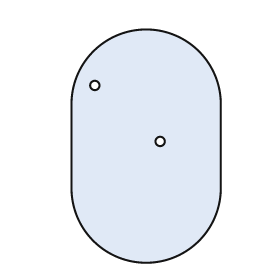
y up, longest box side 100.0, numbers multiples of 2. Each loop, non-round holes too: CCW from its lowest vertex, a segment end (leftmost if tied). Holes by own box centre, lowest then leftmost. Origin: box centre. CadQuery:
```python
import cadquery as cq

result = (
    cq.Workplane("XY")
    .moveTo(-32.0, -18.0)
    .threePointArc((0.0, -50.0), (32.0, -18.0))
    .lineTo(32.0, 18.0)
    .threePointArc((0.0, 50.0), (-32.0, 18.0))
    .close()
    .moveTo(6.0, 2.0)
    .circle(2.0)
    .moveTo(-22.0, 26.0)
    .circle(2.0)
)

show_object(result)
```